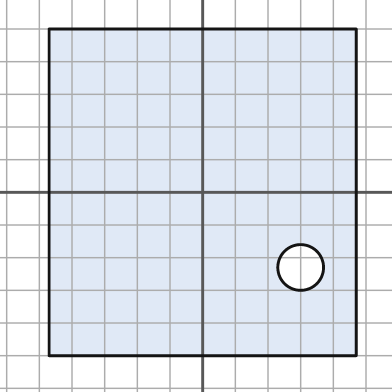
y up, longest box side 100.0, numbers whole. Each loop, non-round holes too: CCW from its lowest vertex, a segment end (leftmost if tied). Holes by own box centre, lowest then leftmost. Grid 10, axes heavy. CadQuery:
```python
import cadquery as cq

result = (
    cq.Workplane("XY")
    .moveTo(-47.0, -50.0)
    .lineTo(47.0, -50.0)
    .lineTo(47.0, 50.0)
    .lineTo(-47.0, 50.0)
    .close()
    .moveTo(30.0, -23.0)
    .circle(7.0)
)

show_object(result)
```